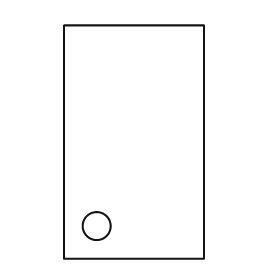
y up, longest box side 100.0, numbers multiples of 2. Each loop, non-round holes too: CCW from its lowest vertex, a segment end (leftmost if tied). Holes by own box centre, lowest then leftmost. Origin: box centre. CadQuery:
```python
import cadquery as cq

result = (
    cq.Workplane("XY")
    .moveTo(-30.0, -50.0)
    .lineTo(30.0, -50.0)
    .lineTo(30.0, 50.0)
    .lineTo(-30.0, 50.0)
    .close()
    .moveTo(-16.0, -36.0)
    .circle(6.0)
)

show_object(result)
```